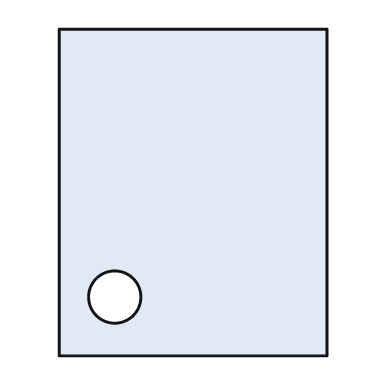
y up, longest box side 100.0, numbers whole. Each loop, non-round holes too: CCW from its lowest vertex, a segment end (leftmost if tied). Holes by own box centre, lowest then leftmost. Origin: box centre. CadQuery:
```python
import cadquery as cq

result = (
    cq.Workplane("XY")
    .moveTo(-41.0, -50.0)
    .lineTo(41.0, -50.0)
    .lineTo(41.0, 50.0)
    .lineTo(-41.0, 50.0)
    .close()
    .moveTo(-24.0, -32.0)
    .circle(8.0)
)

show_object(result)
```